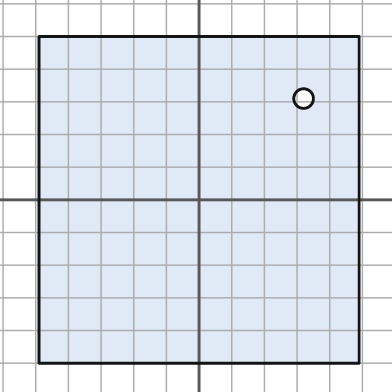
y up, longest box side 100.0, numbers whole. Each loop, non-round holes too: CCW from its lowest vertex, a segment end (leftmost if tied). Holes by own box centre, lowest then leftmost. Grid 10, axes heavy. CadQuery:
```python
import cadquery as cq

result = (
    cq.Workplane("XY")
    .moveTo(-49.0, -50.0)
    .lineTo(49.0, -50.0)
    .lineTo(49.0, 50.0)
    .lineTo(-49.0, 50.0)
    .close()
    .moveTo(32.0, 31.0)
    .circle(3.0)
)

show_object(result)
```